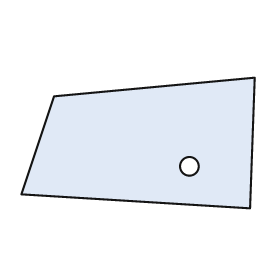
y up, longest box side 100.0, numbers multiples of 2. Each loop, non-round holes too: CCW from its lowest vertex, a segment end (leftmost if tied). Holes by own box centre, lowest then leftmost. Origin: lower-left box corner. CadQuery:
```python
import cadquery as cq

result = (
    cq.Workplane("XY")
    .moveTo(98.0, 0.0)
    .lineTo(100.0, 56.0)
    .lineTo(14.0, 48.0)
    .lineTo(0.0, 6.0)
    .close()
    .moveTo(72.0, 18.0)
    .circle(4.0)
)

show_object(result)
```